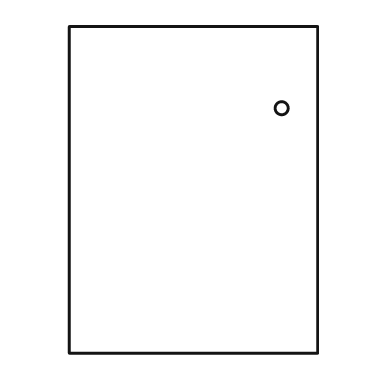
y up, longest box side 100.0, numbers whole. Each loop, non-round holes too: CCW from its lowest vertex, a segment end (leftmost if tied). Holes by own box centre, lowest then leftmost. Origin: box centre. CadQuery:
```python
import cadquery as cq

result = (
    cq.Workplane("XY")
    .moveTo(-38.0, -50.0)
    .lineTo(38.0, -50.0)
    .lineTo(38.0, 50.0)
    .lineTo(-38.0, 50.0)
    .close()
    .moveTo(27.0, 25.0)
    .circle(2.0)
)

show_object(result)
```